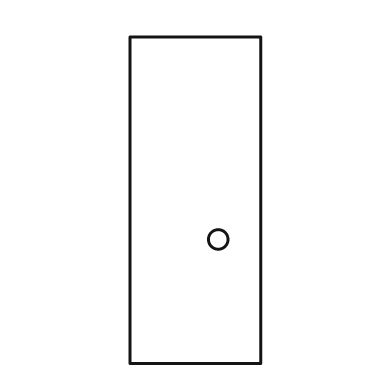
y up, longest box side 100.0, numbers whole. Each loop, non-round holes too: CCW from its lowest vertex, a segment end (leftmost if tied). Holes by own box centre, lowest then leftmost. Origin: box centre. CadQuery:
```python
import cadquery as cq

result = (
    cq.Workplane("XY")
    .moveTo(-20.0, -50.0)
    .lineTo(20.0, -50.0)
    .lineTo(20.0, 50.0)
    .lineTo(-20.0, 50.0)
    .close()
    .moveTo(7.0, -12.0)
    .circle(3.0)
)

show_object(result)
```